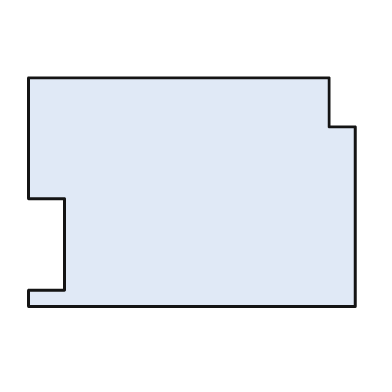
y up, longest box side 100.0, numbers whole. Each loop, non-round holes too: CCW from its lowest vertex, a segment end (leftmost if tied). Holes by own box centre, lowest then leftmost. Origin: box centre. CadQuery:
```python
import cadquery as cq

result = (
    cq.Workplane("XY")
    .moveTo(-50.0, -35.0)
    .lineTo(50.0, -35.0)
    .lineTo(50.0, 20.0)
    .lineTo(42.0, 20.0)
    .lineTo(42.0, 35.0)
    .lineTo(-50.0, 35.0)
    .lineTo(-50.0, -2.0)
    .lineTo(-39.0, -2.0)
    .lineTo(-39.0, -30.0)
    .lineTo(-50.0, -30.0)
    .close()
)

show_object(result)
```